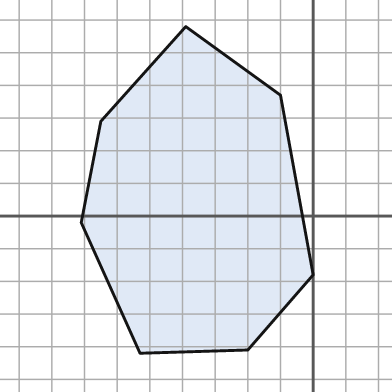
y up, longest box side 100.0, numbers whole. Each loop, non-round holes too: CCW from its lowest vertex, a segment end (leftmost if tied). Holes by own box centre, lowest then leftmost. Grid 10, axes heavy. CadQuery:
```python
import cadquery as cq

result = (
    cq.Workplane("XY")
    .moveTo(-53.0, -42.0)
    .lineTo(-20.0, -41.0)
    .lineTo(0.0, -18.0)
    .lineTo(-10.0, 37.0)
    .lineTo(-39.0, 58.0)
    .lineTo(-65.0, 29.0)
    .lineTo(-71.0, -2.0)
    .close()
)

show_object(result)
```